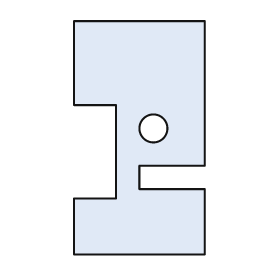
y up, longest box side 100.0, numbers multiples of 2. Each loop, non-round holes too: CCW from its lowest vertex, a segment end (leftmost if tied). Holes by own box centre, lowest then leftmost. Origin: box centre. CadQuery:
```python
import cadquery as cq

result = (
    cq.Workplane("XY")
    .moveTo(-28.0, -50.0)
    .lineTo(28.0, -50.0)
    .lineTo(28.0, -22.0)
    .lineTo(0.0, -22.0)
    .lineTo(0.0, -12.0)
    .lineTo(28.0, -12.0)
    .lineTo(28.0, 50.0)
    .lineTo(-28.0, 50.0)
    .lineTo(-28.0, 14.0)
    .lineTo(-10.0, 14.0)
    .lineTo(-10.0, -26.0)
    .lineTo(-28.0, -26.0)
    .close()
    .moveTo(6.0, 4.0)
    .circle(6.0)
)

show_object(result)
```